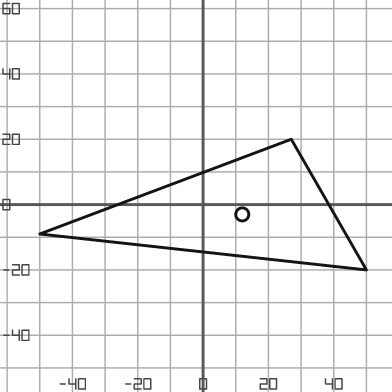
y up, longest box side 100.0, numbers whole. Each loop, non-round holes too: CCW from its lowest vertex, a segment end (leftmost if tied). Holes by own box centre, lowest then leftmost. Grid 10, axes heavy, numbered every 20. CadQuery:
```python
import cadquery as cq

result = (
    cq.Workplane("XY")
    .moveTo(50.0, -20.0)
    .lineTo(27.0, 20.0)
    .lineTo(-50.0, -9.0)
    .close()
    .moveTo(12.0, -3.0)
    .circle(2.0)
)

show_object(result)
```